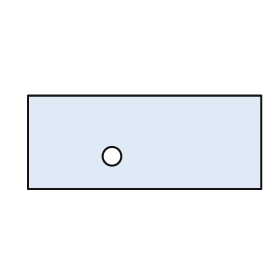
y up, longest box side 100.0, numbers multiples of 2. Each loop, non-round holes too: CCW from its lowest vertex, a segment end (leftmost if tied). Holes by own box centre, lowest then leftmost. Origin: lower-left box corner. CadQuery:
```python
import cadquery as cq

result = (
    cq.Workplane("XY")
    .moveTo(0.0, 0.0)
    .lineTo(100.0, 0.0)
    .lineTo(100.0, 40.0)
    .lineTo(0.0, 40.0)
    .close()
    .moveTo(36.0, 14.0)
    .circle(4.0)
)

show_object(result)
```